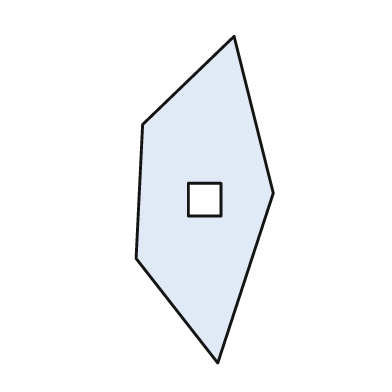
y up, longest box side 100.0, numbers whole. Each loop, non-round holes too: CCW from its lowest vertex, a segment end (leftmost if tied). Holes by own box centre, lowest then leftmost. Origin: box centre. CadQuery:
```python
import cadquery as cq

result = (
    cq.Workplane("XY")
    .moveTo(4.0, -50.0)
    .lineTo(21.0, 2.0)
    .lineTo(9.0, 50.0)
    .lineTo(-19.0, 23.0)
    .lineTo(-21.0, -18.0)
    .close()
    .moveTo(-5.0, -5.0)
    .lineTo(5.0, -5.0)
    .lineTo(5.0, 5.0)
    .lineTo(-5.0, 5.0)
    .close()
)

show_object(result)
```